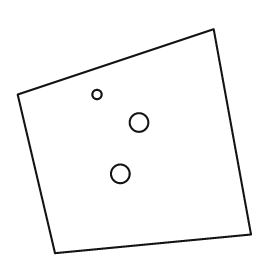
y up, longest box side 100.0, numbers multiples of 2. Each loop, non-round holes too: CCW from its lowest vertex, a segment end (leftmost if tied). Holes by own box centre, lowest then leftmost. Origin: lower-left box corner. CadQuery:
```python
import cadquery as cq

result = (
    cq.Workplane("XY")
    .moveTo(16.0, 0.0)
    .lineTo(100.0, 8.0)
    .lineTo(84.0, 96.0)
    .lineTo(0.0, 68.0)
    .close()
    .moveTo(44.0, 34.0)
    .circle(4.0)
    .moveTo(52.0, 56.0)
    .circle(4.0)
    .moveTo(34.0, 68.0)
    .circle(2.0)
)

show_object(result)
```